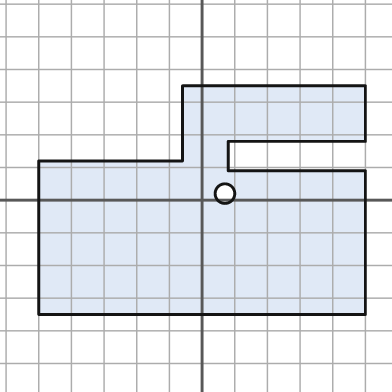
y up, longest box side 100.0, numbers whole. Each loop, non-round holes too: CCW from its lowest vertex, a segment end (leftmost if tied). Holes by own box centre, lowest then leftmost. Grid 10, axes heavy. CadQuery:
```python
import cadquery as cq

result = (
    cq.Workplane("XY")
    .moveTo(-50.0, -35.0)
    .lineTo(50.0, -35.0)
    .lineTo(50.0, 9.0)
    .lineTo(8.0, 9.0)
    .lineTo(8.0, 18.0)
    .lineTo(50.0, 18.0)
    .lineTo(50.0, 35.0)
    .lineTo(-6.0, 35.0)
    .lineTo(-6.0, 12.0)
    .lineTo(-50.0, 12.0)
    .close()
    .moveTo(7.0, 2.0)
    .circle(3.0)
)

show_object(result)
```